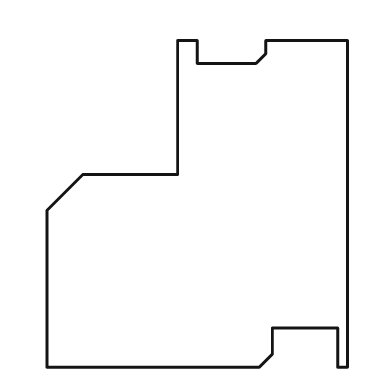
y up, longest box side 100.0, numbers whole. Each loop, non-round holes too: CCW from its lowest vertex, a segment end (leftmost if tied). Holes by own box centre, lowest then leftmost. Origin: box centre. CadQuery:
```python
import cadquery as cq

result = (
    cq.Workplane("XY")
    .moveTo(-46.0, -50.0)
    .lineTo(19.0, -50.0)
    .lineTo(23.0, -46.0)
    .lineTo(23.0, -38.0)
    .lineTo(43.0, -38.0)
    .lineTo(43.0, -50.0)
    .lineTo(46.0, -50.0)
    .lineTo(46.0, 50.0)
    .lineTo(21.0, 50.0)
    .lineTo(21.0, 46.0)
    .lineTo(18.0, 43.0)
    .lineTo(0.0, 43.0)
    .lineTo(0.0, 50.0)
    .lineTo(-6.0, 50.0)
    .lineTo(-6.0, 9.0)
    .lineTo(-35.0, 9.0)
    .lineTo(-46.0, -2.0)
    .close()
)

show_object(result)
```